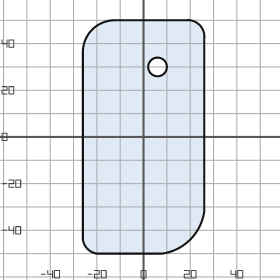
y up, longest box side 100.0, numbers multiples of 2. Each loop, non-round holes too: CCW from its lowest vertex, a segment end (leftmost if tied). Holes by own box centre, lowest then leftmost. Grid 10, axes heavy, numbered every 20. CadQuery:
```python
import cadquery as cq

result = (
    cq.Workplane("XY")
    .moveTo(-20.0, -50.0)
    .lineTo(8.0, -50.0)
    .threePointArc((20.0, -44.0), (26.0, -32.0))
    .lineTo(26.0, 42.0)
    .threePointArc((24.0, 48.0), (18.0, 50.0))
    .lineTo(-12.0, 50.0)
    .threePointArc((-22.0, 46.0), (-26.0, 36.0))
    .lineTo(-26.0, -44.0)
    .threePointArc((-24.0, -48.0), (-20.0, -50.0))
    .close()
    .moveTo(6.0, 30.0)
    .circle(4.0)
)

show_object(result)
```